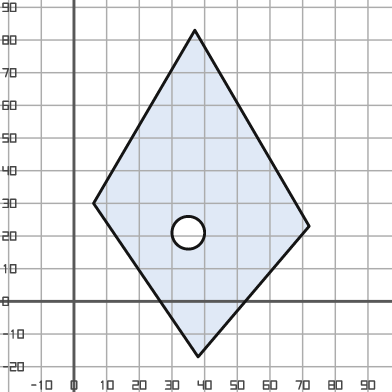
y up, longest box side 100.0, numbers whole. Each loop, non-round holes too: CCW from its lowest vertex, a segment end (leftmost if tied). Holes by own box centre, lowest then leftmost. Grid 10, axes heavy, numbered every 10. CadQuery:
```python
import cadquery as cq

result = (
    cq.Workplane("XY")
    .moveTo(38.0, -17.0)
    .lineTo(72.0, 23.0)
    .lineTo(37.0, 83.0)
    .lineTo(6.0, 30.0)
    .close()
    .moveTo(35.0, 21.0)
    .circle(5.0)
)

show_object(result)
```